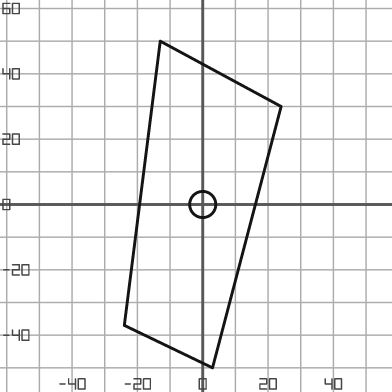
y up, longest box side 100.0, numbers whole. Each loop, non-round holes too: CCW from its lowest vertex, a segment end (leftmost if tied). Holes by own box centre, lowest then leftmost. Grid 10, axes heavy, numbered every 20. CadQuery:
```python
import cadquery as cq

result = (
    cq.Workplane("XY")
    .moveTo(3.0, -50.0)
    .lineTo(24.0, 30.0)
    .lineTo(-13.0, 50.0)
    .lineTo(-24.0, -37.0)
    .close()
    .moveTo(0.0, 0.0)
    .circle(4.0)
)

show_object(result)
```